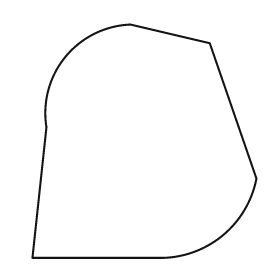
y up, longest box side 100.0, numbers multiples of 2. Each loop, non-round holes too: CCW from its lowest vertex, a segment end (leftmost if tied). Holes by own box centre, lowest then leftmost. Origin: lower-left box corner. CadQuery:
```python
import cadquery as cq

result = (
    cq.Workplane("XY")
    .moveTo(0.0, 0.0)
    .lineTo(56.0, 0.0)
    .threePointArc((82.0, 10.0), (96.0, 34.0))
    .lineTo(76.0, 92.0)
    .lineTo(42.0, 100.0)
    .threePointArc((14.0, 86.0), (6.0, 56.0))
    .close()
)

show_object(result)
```